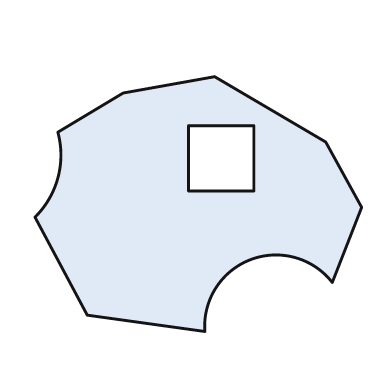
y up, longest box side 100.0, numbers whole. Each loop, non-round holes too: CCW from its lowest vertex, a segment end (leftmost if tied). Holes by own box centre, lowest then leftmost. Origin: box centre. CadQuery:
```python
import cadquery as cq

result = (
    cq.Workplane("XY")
    .moveTo(2.0, -39.0)
    .threePointArc((16.0, -17.0), (41.0, -24.0))
    .lineTo(50.0, -1.0)
    .lineTo(39.0, 19.0)
    .lineTo(5.0, 39.0)
    .lineTo(-23.0, 34.0)
    .lineTo(-43.0, 22.0)
    .threePointArc((-43.0, 8.0), (-50.0, -4.0))
    .lineTo(-34.0, -34.0)
    .close()
    .moveTo(-3.0, 4.0)
    .lineTo(17.0, 4.0)
    .lineTo(17.0, 24.0)
    .lineTo(-3.0, 24.0)
    .close()
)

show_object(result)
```